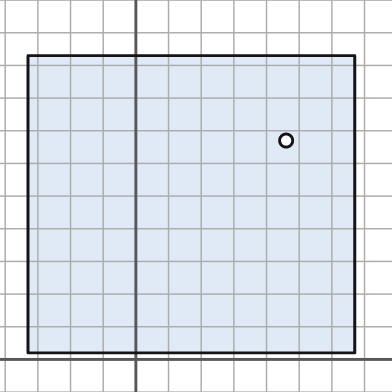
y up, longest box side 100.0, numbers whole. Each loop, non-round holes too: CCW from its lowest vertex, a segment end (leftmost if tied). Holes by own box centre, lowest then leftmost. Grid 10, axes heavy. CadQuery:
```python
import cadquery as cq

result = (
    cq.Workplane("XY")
    .moveTo(-33.0, 2.0)
    .lineTo(67.0, 2.0)
    .lineTo(67.0, 93.0)
    .lineTo(-33.0, 93.0)
    .close()
    .moveTo(46.0, 67.0)
    .circle(2.0)
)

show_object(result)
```